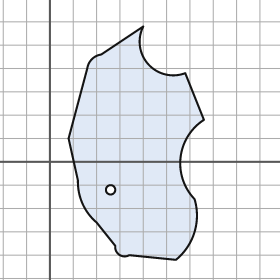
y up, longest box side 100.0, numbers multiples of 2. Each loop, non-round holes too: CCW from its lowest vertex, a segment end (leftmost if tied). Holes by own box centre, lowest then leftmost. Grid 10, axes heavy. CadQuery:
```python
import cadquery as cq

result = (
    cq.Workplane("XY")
    .moveTo(54.0, -42.0)
    .threePointArc((62.0, -30.0), (62.0, -16.0))
    .threePointArc((56.0, 2.0), (66.0, 18.0))
    .lineTo(58.0, 38.0)
    .threePointArc((42.0, 42.0), (40.0, 58.0))
    .lineTo(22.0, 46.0)
    .threePointArc((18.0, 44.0), (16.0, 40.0))
    .lineTo(8.0, 10.0)
    .lineTo(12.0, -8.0)
    .threePointArc((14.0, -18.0), (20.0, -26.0))
    .lineTo(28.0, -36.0)
    .threePointArc((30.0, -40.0), (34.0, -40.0))
    .close()
    .moveTo(26.0, -12.0)
    .circle(2.0)
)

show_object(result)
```